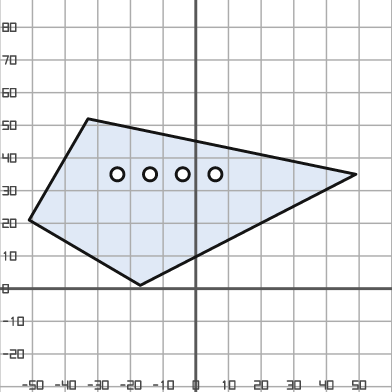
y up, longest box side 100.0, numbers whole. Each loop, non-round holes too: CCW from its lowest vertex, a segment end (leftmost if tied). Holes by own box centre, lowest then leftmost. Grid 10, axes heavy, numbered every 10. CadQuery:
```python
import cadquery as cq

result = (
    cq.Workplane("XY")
    .moveTo(-17.0, 1.0)
    .lineTo(49.0, 35.0)
    .lineTo(-33.0, 52.0)
    .lineTo(-51.0, 21.0)
    .close()
    .moveTo(-24.0, 35.0)
    .circle(2.0)
    .moveTo(-14.0, 35.0)
    .circle(2.0)
    .moveTo(-4.0, 35.0)
    .circle(2.0)
    .moveTo(6.0, 35.0)
    .circle(2.0)
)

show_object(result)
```